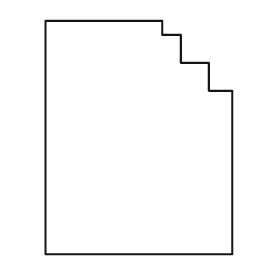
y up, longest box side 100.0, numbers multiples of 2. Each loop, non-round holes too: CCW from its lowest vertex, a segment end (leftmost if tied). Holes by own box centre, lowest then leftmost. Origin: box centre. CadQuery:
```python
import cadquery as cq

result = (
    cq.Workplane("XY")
    .moveTo(-40.0, -50.0)
    .lineTo(40.0, -50.0)
    .lineTo(40.0, 20.0)
    .lineTo(30.0, 20.0)
    .lineTo(30.0, 32.0)
    .lineTo(18.0, 32.0)
    .lineTo(18.0, 44.0)
    .lineTo(10.0, 44.0)
    .lineTo(10.0, 50.0)
    .lineTo(-40.0, 50.0)
    .close()
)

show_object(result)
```